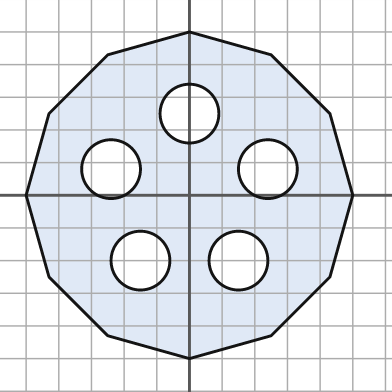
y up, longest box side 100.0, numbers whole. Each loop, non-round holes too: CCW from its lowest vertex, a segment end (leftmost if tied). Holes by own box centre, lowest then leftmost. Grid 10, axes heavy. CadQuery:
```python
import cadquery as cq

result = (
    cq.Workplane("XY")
    .moveTo(0.0, -50.0)
    .lineTo(25.0, -43.0)
    .lineTo(43.0, -25.0)
    .lineTo(50.0, 0.0)
    .lineTo(43.0, 25.0)
    .lineTo(25.0, 43.0)
    .lineTo(0.0, 50.0)
    .lineTo(-25.0, 43.0)
    .lineTo(-43.0, 25.0)
    .lineTo(-50.0, 0.0)
    .lineTo(-43.0, -25.0)
    .lineTo(-25.0, -43.0)
    .close()
    .moveTo(-15.0, -20.0)
    .circle(9.0)
    .moveTo(15.0, -20.0)
    .circle(9.0)
    .moveTo(-24.0, 8.0)
    .circle(9.0)
    .moveTo(24.0, 8.0)
    .circle(9.0)
    .moveTo(0.0, 25.0)
    .circle(9.0)
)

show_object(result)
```